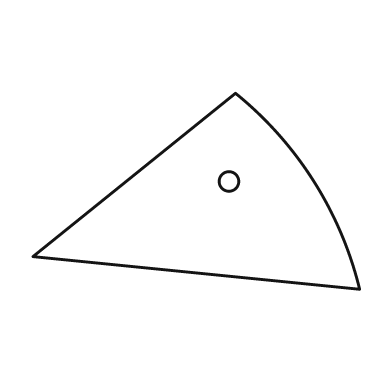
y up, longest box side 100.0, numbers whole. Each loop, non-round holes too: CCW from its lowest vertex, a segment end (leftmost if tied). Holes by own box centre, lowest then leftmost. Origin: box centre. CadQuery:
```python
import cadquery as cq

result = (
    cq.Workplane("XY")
    .moveTo(50.0, -30.0)
    .threePointArc((36.0, 3.0), (12.0, 30.0))
    .lineTo(-50.0, -20.0)
    .close()
    .moveTo(10.0, 3.0)
    .circle(3.0)
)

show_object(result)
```